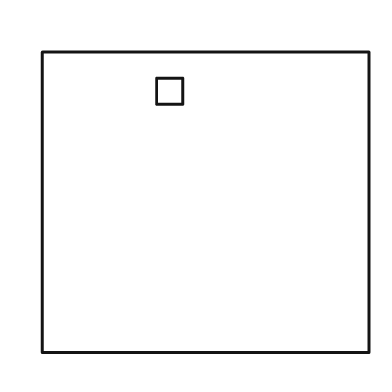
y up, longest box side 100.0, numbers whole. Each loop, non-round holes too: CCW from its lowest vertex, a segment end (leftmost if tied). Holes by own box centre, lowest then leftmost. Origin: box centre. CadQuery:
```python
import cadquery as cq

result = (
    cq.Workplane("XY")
    .moveTo(-50.0, -46.0)
    .lineTo(50.0, -46.0)
    .lineTo(50.0, 46.0)
    .lineTo(-50.0, 46.0)
    .close()
    .moveTo(-15.0, 30.0)
    .lineTo(-7.0, 30.0)
    .lineTo(-7.0, 38.0)
    .lineTo(-15.0, 38.0)
    .close()
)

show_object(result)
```